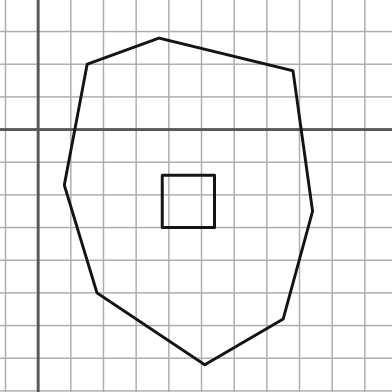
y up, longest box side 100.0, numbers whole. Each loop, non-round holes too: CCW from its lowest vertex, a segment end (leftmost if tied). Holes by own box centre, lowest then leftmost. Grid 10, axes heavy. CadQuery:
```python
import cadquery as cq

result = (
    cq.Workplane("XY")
    .moveTo(51.0, -72.0)
    .lineTo(75.0, -58.0)
    .lineTo(84.0, -25.0)
    .lineTo(78.0, 18.0)
    .lineTo(37.0, 28.0)
    .lineTo(15.0, 20.0)
    .lineTo(8.0, -17.0)
    .lineTo(18.0, -50.0)
    .close()
    .moveTo(38.0, -30.0)
    .lineTo(54.0, -30.0)
    .lineTo(54.0, -14.0)
    .lineTo(38.0, -14.0)
    .close()
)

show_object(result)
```